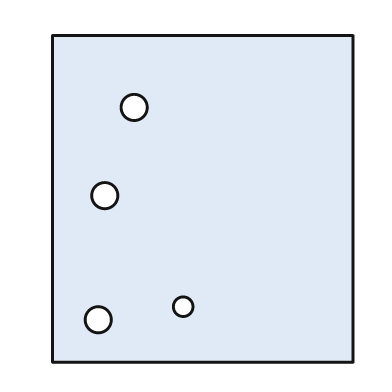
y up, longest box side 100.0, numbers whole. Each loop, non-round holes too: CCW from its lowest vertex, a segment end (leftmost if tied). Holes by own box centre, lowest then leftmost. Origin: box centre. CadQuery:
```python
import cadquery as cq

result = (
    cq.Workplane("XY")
    .moveTo(-46.0, -50.0)
    .lineTo(46.0, -50.0)
    .lineTo(46.0, 50.0)
    .lineTo(-46.0, 50.0)
    .close()
    .moveTo(-32.0, -37.0)
    .circle(4.0)
    .moveTo(-6.0, -33.0)
    .circle(3.0)
    .moveTo(-30.0, 1.0)
    .circle(4.0)
    .moveTo(-21.0, 28.0)
    .circle(4.0)
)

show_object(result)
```